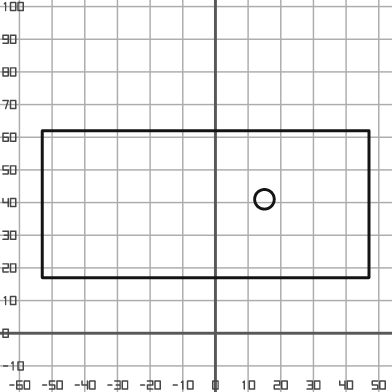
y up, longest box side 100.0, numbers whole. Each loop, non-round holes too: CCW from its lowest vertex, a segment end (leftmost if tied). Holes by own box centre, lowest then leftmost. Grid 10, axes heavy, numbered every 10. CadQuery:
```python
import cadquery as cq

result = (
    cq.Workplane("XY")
    .moveTo(-53.0, 17.0)
    .lineTo(47.0, 17.0)
    .lineTo(47.0, 62.0)
    .lineTo(-53.0, 62.0)
    .close()
    .moveTo(15.0, 41.0)
    .circle(3.0)
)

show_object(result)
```